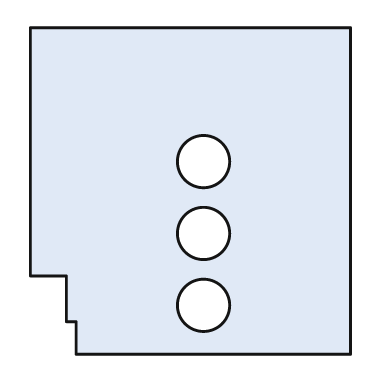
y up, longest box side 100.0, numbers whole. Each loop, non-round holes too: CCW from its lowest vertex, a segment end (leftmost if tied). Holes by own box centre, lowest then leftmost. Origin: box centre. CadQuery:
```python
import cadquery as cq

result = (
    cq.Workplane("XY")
    .moveTo(-35.0, -50.0)
    .lineTo(49.0, -50.0)
    .lineTo(49.0, 50.0)
    .lineTo(-49.0, 50.0)
    .lineTo(-49.0, -26.0)
    .lineTo(-38.0, -26.0)
    .lineTo(-38.0, -40.0)
    .lineTo(-35.0, -40.0)
    .close()
    .moveTo(4.0, -35.0)
    .circle(8.0)
    .moveTo(4.0, -13.0)
    .circle(8.0)
    .moveTo(4.0, 9.0)
    .circle(8.0)
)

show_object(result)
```